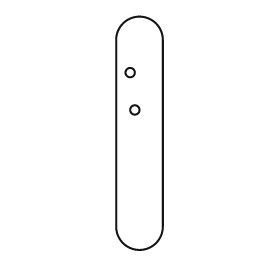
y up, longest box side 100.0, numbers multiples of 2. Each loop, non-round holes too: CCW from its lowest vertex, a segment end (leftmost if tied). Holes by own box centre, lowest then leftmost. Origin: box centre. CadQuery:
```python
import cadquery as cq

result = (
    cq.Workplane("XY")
    .moveTo(-10.0, -40.0)
    .threePointArc((0.0, -50.0), (10.0, -40.0))
    .lineTo(10.0, 40.0)
    .threePointArc((0.0, 50.0), (-10.0, 40.0))
    .close()
    .moveTo(-2.0, 10.0)
    .circle(2.0)
    .moveTo(-4.0, 26.0)
    .circle(2.0)
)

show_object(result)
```